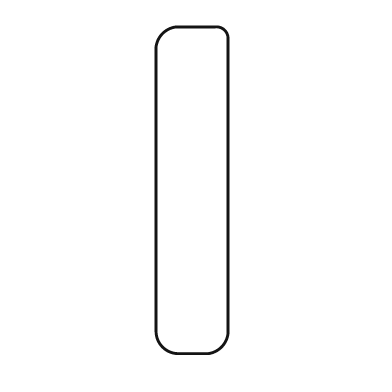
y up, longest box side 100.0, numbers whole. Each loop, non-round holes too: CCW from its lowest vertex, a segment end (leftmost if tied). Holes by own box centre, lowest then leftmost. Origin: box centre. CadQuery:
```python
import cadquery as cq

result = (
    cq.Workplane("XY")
    .moveTo(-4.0, -50.0)
    .lineTo(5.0, -50.0)
    .threePointArc((9.0, -48.0), (11.0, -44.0))
    .lineTo(11.0, 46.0)
    .threePointArc((10.0, 49.0), (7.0, 50.0))
    .lineTo(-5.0, 50.0)
    .threePointArc((-9.0, 48.0), (-11.0, 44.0))
    .lineTo(-11.0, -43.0)
    .threePointArc((-9.0, -48.0), (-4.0, -50.0))
    .close()
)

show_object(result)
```